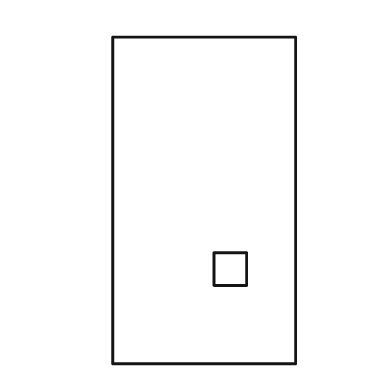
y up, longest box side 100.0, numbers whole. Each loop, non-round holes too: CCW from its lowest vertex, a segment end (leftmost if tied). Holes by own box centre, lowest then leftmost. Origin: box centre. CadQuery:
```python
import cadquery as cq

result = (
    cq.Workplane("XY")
    .moveTo(-28.0, -50.0)
    .lineTo(28.0, -50.0)
    .lineTo(28.0, 50.0)
    .lineTo(-28.0, 50.0)
    .close()
    .moveTo(3.0, -26.0)
    .lineTo(13.0, -26.0)
    .lineTo(13.0, -16.0)
    .lineTo(3.0, -16.0)
    .close()
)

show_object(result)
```